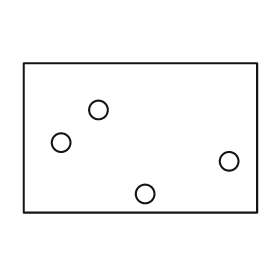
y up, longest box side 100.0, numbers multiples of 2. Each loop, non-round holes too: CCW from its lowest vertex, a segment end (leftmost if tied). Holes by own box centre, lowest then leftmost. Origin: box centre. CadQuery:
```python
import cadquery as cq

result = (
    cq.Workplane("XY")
    .moveTo(-50.0, -32.0)
    .lineTo(50.0, -32.0)
    .lineTo(50.0, 32.0)
    .lineTo(-50.0, 32.0)
    .close()
    .moveTo(2.0, -24.0)
    .circle(4.0)
    .moveTo(38.0, -10.0)
    .circle(4.0)
    .moveTo(-34.0, -2.0)
    .circle(4.0)
    .moveTo(-18.0, 12.0)
    .circle(4.0)
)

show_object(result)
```